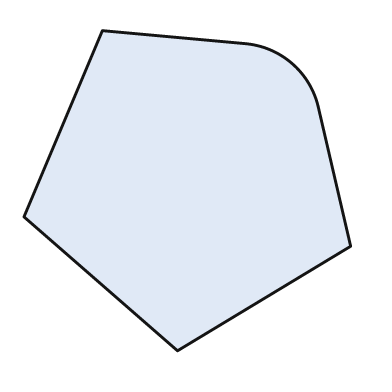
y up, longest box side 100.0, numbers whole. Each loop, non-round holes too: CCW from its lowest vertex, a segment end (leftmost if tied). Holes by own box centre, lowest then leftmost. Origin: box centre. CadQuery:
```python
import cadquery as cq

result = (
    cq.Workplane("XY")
    .moveTo(-3.0, -49.0)
    .lineTo(50.0, -17.0)
    .lineTo(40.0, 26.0)
    .threePointArc((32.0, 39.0), (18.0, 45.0))
    .lineTo(-26.0, 49.0)
    .lineTo(-50.0, -8.0)
    .close()
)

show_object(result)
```